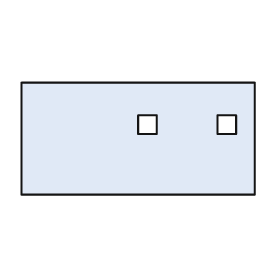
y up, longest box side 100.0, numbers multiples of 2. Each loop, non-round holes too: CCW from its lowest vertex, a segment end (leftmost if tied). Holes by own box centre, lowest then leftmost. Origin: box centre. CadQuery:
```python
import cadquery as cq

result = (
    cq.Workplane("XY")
    .moveTo(-50.0, -24.0)
    .lineTo(50.0, -24.0)
    .lineTo(50.0, 24.0)
    .lineTo(-50.0, 24.0)
    .close()
    .moveTo(0.0, 2.0)
    .lineTo(8.0, 2.0)
    .lineTo(8.0, 10.0)
    .lineTo(0.0, 10.0)
    .close()
    .moveTo(34.0, 2.0)
    .lineTo(42.0, 2.0)
    .lineTo(42.0, 10.0)
    .lineTo(34.0, 10.0)
    .close()
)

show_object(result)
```